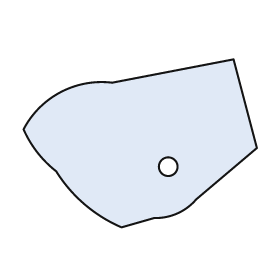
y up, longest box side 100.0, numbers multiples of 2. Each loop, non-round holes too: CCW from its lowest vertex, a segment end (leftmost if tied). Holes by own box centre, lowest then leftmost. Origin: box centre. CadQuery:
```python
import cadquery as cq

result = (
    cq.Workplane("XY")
    .moveTo(-8.0, -36.0)
    .lineTo(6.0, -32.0)
    .threePointArc((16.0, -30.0), (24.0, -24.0))
    .lineTo(50.0, -2.0)
    .lineTo(40.0, 36.0)
    .lineTo(-12.0, 26.0)
    .threePointArc((-34.0, 22.0), (-50.0, 6.0))
    .threePointArc((-44.0, -4.0), (-36.0, -12.0))
    .threePointArc((-24.0, -26.0), (-8.0, -36.0))
    .close()
    .moveTo(12.0, -10.0)
    .circle(4.0)
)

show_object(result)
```